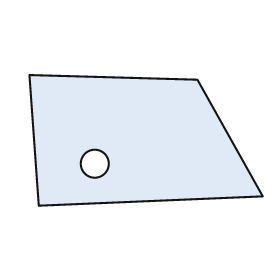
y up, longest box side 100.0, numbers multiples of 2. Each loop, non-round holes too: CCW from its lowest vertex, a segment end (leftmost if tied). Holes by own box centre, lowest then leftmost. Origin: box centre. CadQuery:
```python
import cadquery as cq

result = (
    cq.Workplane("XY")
    .moveTo(-46.0, -28.0)
    .lineTo(50.0, -24.0)
    .lineTo(22.0, 26.0)
    .lineTo(-50.0, 28.0)
    .close()
    .moveTo(-22.0, -10.0)
    .circle(6.0)
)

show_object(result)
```